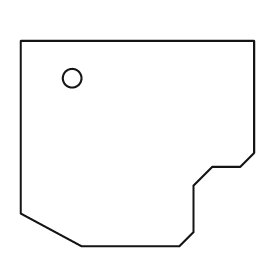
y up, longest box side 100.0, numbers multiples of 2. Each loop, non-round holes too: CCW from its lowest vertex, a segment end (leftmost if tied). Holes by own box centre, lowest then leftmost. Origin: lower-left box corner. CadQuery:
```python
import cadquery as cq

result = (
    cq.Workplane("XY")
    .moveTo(26.0, 0.0)
    .lineTo(68.0, 0.0)
    .lineTo(74.0, 6.0)
    .lineTo(74.0, 26.0)
    .lineTo(82.0, 34.0)
    .lineTo(94.0, 34.0)
    .lineTo(100.0, 40.0)
    .lineTo(100.0, 88.0)
    .lineTo(0.0, 88.0)
    .lineTo(0.0, 14.0)
    .close()
    .moveTo(22.0, 72.0)
    .circle(4.0)
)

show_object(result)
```